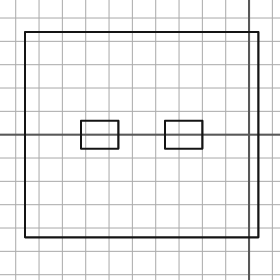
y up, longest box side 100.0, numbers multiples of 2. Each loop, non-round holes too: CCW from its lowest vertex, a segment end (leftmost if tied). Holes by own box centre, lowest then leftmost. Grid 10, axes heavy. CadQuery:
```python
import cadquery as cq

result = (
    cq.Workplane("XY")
    .moveTo(-96.0, -44.0)
    .lineTo(4.0, -44.0)
    .lineTo(4.0, 44.0)
    .lineTo(-96.0, 44.0)
    .close()
    .moveTo(-72.0, -6.0)
    .lineTo(-56.0, -6.0)
    .lineTo(-56.0, 6.0)
    .lineTo(-72.0, 6.0)
    .close()
    .moveTo(-36.0, -6.0)
    .lineTo(-20.0, -6.0)
    .lineTo(-20.0, 6.0)
    .lineTo(-36.0, 6.0)
    .close()
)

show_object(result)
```